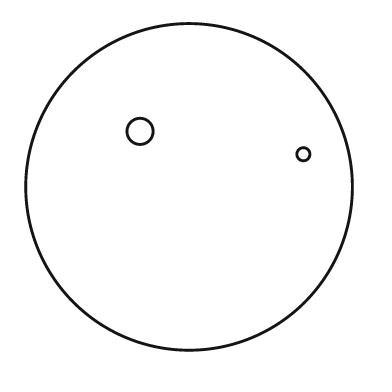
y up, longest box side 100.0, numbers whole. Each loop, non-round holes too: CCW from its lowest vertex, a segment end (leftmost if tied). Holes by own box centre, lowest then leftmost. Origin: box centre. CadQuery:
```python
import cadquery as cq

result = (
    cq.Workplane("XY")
    .moveTo(0.0, 0.0)
    .circle(50.0)
    .moveTo(35.0, 10.0)
    .circle(2.0)
    .moveTo(-15.0, 17.0)
    .circle(4.0)
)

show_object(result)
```